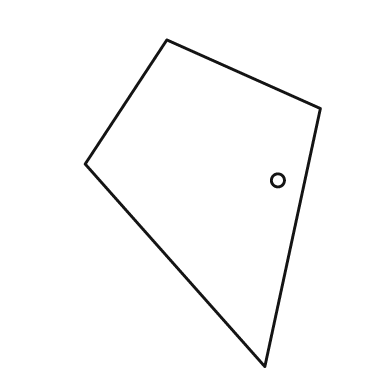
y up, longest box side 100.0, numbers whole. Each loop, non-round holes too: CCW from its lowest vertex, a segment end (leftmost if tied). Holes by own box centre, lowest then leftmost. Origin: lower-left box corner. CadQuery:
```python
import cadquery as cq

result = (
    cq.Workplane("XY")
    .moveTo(55.0, 0.0)
    .lineTo(72.0, 79.0)
    .lineTo(25.0, 100.0)
    .lineTo(0.0, 62.0)
    .close()
    .moveTo(59.0, 57.0)
    .circle(2.0)
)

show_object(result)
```